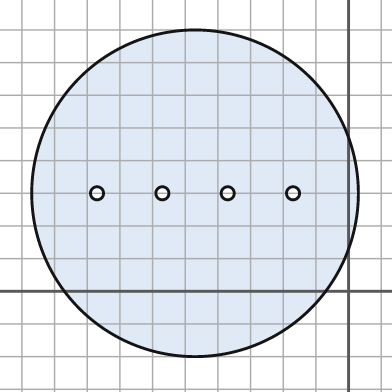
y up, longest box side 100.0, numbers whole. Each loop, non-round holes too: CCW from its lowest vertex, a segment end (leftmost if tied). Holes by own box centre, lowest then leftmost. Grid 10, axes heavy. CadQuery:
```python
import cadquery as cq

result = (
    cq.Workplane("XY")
    .moveTo(-47.0, 30.0)
    .circle(50.0)
    .moveTo(-77.0, 30.0)
    .circle(2.0)
    .moveTo(-57.0, 30.0)
    .circle(2.0)
    .moveTo(-37.0, 30.0)
    .circle(2.0)
    .moveTo(-17.0, 30.0)
    .circle(2.0)
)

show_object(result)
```